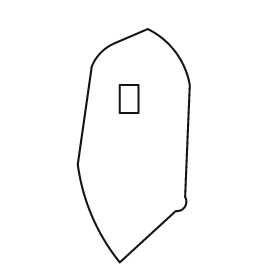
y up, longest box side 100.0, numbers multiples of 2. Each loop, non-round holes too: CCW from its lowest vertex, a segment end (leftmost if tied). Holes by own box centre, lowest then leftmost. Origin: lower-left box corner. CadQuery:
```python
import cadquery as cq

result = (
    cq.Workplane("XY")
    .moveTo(18.0, 0.0)
    .lineTo(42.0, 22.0)
    .threePointArc((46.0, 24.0), (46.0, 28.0))
    .lineTo(48.0, 76.0)
    .threePointArc((42.0, 90.0), (30.0, 100.0))
    .lineTo(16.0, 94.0)
    .threePointArc((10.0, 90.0), (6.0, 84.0))
    .lineTo(0.0, 42.0)
    .threePointArc((6.0, 20.0), (18.0, 0.0))
    .close()
    .moveTo(18.0, 64.0)
    .lineTo(26.0, 64.0)
    .lineTo(26.0, 76.0)
    .lineTo(18.0, 76.0)
    .close()
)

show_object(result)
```